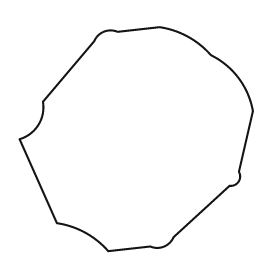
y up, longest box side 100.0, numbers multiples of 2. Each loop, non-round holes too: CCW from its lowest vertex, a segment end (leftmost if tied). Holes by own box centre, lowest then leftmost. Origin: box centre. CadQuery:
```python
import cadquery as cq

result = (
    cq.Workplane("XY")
    .moveTo(-12.0, -48.0)
    .lineTo(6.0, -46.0)
    .threePointArc((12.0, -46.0), (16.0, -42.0))
    .lineTo(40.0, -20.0)
    .threePointArc((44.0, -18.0), (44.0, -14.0))
    .lineTo(50.0, 12.0)
    .threePointArc((44.0, 26.0), (32.0, 36.0))
    .threePointArc((22.0, 44.0), (10.0, 48.0))
    .lineTo(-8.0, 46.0)
    .threePointArc((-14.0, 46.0), (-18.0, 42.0))
    .lineTo(-40.0, 16.0)
    .threePointArc((-42.0, 6.0), (-50.0, 0.0))
    .lineTo(-34.0, -36.0)
    .threePointArc((-22.0, -40.0), (-12.0, -48.0))
    .close()
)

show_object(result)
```